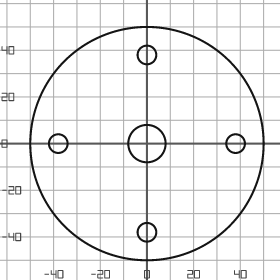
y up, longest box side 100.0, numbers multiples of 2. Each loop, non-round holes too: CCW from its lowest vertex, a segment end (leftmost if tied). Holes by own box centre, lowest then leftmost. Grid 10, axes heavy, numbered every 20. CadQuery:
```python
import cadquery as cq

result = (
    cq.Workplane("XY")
    .moveTo(0.0, 0.0)
    .circle(50.0)
    .moveTo(0.0, -38.0)
    .circle(4.0)
    .moveTo(-38.0, 0.0)
    .circle(4.0)
    .moveTo(0.0, 0.0)
    .circle(8.0)
    .moveTo(38.0, 0.0)
    .circle(4.0)
    .moveTo(0.0, 38.0)
    .circle(4.0)
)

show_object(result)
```